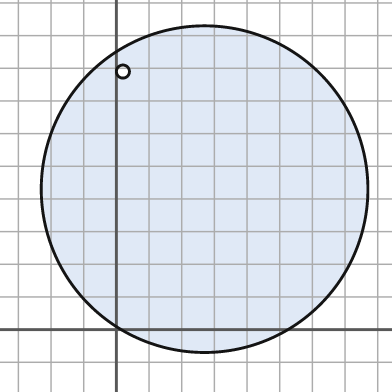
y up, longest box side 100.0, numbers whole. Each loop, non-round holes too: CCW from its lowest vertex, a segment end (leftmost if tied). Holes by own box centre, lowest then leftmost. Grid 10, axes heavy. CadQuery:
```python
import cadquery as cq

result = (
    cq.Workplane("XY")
    .moveTo(27.0, 43.0)
    .circle(50.0)
    .moveTo(2.0, 79.0)
    .circle(2.0)
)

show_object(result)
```